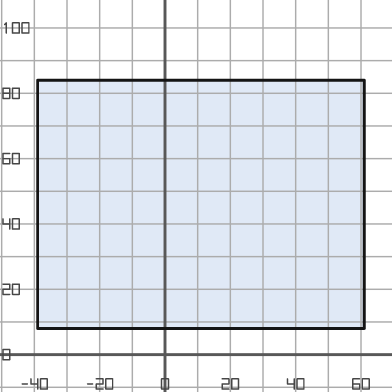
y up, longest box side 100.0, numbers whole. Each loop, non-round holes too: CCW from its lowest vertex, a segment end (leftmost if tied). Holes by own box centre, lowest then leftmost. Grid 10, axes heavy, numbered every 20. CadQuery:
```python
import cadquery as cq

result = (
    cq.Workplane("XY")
    .moveTo(-39.0, 8.0)
    .lineTo(61.0, 8.0)
    .lineTo(61.0, 84.0)
    .lineTo(-39.0, 84.0)
    .close()
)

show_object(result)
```